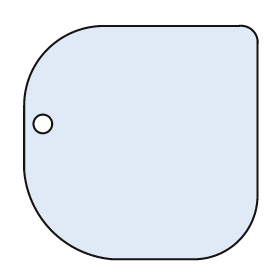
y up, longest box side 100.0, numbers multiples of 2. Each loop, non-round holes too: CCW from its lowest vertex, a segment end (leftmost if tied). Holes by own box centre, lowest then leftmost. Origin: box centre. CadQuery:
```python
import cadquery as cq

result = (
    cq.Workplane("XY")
    .moveTo(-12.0, -50.0)
    .lineTo(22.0, -50.0)
    .threePointArc((42.0, -42.0), (50.0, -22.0))
    .lineTo(50.0, 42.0)
    .threePointArc((48.0, 48.0), (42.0, 50.0))
    .lineTo(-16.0, 50.0)
    .threePointArc((-40.0, 40.0), (-50.0, 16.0))
    .lineTo(-50.0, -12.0)
    .threePointArc((-38.0, -38.0), (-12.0, -50.0))
    .close()
    .moveTo(-42.0, 8.0)
    .circle(4.0)
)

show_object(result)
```